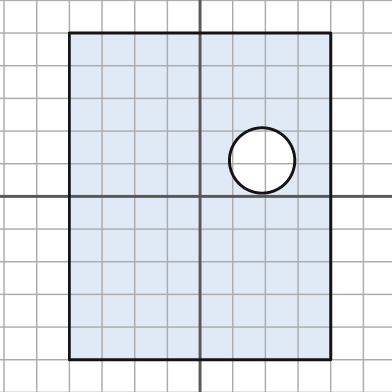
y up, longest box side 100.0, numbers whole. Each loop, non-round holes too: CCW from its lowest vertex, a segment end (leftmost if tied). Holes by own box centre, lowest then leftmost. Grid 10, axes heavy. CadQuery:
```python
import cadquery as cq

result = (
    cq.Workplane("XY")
    .moveTo(-40.0, -50.0)
    .lineTo(40.0, -50.0)
    .lineTo(40.0, 50.0)
    .lineTo(-40.0, 50.0)
    .close()
    .moveTo(19.0, 11.0)
    .circle(10.0)
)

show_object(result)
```